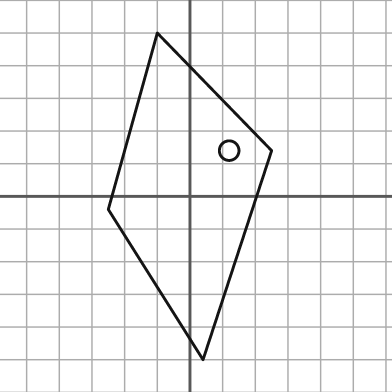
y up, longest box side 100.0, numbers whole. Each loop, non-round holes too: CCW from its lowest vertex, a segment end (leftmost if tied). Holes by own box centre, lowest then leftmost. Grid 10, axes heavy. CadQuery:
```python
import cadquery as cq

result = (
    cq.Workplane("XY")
    .moveTo(4.0, -50.0)
    .lineTo(25.0, 14.0)
    .lineTo(-10.0, 50.0)
    .lineTo(-25.0, -4.0)
    .close()
    .moveTo(12.0, 14.0)
    .circle(3.0)
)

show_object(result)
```